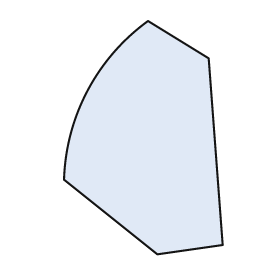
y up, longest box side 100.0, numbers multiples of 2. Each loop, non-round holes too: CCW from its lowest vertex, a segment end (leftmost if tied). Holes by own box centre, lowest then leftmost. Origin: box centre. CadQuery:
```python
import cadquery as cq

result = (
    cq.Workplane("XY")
    .moveTo(6.0, -50.0)
    .lineTo(34.0, -46.0)
    .lineTo(28.0, 34.0)
    .lineTo(2.0, 50.0)
    .threePointArc((-24.0, 20.0), (-34.0, -18.0))
    .close()
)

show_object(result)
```